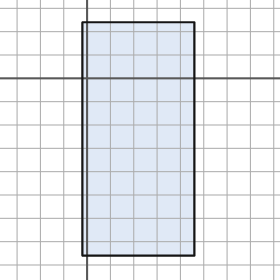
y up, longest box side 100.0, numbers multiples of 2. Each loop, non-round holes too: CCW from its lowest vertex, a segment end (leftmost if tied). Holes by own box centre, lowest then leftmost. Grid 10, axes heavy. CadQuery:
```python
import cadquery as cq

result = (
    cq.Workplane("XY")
    .moveTo(-2.0, -76.0)
    .lineTo(46.0, -76.0)
    .lineTo(46.0, 24.0)
    .lineTo(-2.0, 24.0)
    .close()
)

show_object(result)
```